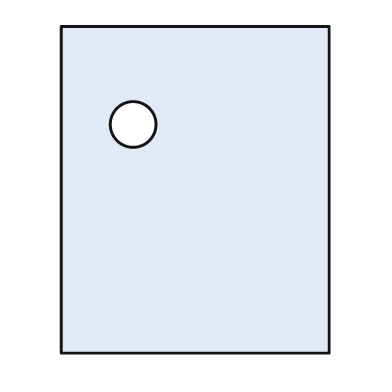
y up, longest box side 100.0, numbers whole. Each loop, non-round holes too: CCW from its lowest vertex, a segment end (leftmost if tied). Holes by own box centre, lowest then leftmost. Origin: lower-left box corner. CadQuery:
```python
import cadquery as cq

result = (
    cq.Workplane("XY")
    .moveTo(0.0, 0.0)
    .lineTo(82.0, 0.0)
    .lineTo(82.0, 100.0)
    .lineTo(0.0, 100.0)
    .close()
    .moveTo(22.0, 70.0)
    .circle(7.0)
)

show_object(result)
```